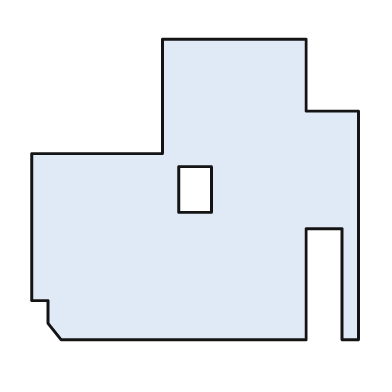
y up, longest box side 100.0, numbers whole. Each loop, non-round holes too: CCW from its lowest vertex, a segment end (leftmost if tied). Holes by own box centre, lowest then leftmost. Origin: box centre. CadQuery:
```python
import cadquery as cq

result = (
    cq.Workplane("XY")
    .moveTo(-41.0, -46.0)
    .lineTo(34.0, -46.0)
    .lineTo(34.0, -12.0)
    .lineTo(45.0, -12.0)
    .lineTo(45.0, -46.0)
    .lineTo(50.0, -46.0)
    .lineTo(50.0, 24.0)
    .lineTo(34.0, 24.0)
    .lineTo(34.0, 46.0)
    .lineTo(-10.0, 46.0)
    .lineTo(-10.0, 11.0)
    .lineTo(-50.0, 11.0)
    .lineTo(-50.0, -34.0)
    .lineTo(-45.0, -34.0)
    .lineTo(-45.0, -41.0)
    .close()
    .moveTo(-5.0, -7.0)
    .lineTo(5.0, -7.0)
    .lineTo(5.0, 7.0)
    .lineTo(-5.0, 7.0)
    .close()
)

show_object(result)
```